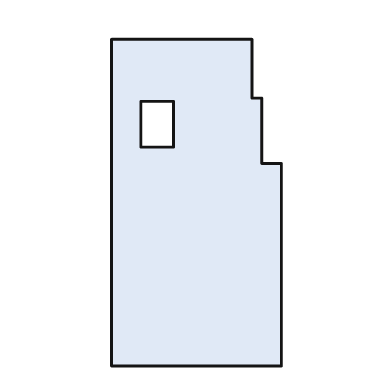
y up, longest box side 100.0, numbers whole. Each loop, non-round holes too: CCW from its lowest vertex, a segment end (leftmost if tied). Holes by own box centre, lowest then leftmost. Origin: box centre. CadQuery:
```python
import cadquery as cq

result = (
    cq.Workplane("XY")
    .moveTo(-26.0, -50.0)
    .lineTo(26.0, -50.0)
    .lineTo(26.0, 12.0)
    .lineTo(20.0, 12.0)
    .lineTo(20.0, 32.0)
    .lineTo(17.0, 32.0)
    .lineTo(17.0, 50.0)
    .lineTo(-26.0, 50.0)
    .close()
    .moveTo(-17.0, 17.0)
    .lineTo(-7.0, 17.0)
    .lineTo(-7.0, 31.0)
    .lineTo(-17.0, 31.0)
    .close()
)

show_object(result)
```